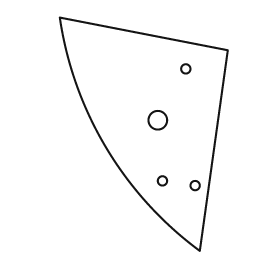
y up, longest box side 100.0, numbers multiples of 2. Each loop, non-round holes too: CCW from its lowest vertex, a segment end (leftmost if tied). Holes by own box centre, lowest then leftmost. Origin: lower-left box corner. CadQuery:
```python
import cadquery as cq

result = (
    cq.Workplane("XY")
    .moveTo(60.0, 0.0)
    .lineTo(72.0, 86.0)
    .lineTo(0.0, 100.0)
    .threePointArc((20.0, 44.0), (60.0, 0.0))
    .close()
    .moveTo(58.0, 28.0)
    .circle(2.0)
    .moveTo(44.0, 30.0)
    .circle(2.0)
    .moveTo(42.0, 56.0)
    .circle(4.0)
    .moveTo(54.0, 78.0)
    .circle(2.0)
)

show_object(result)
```